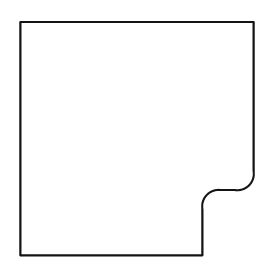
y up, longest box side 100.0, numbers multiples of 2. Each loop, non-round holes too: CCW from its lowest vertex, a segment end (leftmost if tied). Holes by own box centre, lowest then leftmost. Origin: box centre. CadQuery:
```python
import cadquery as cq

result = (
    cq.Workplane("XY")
    .moveTo(-50.0, -50.0)
    .lineTo(28.0, -50.0)
    .lineTo(28.0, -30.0)
    .threePointArc((30.0, -24.0), (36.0, -22.0))
    .lineTo(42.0, -22.0)
    .threePointArc((48.0, -20.0), (50.0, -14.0))
    .lineTo(50.0, 50.0)
    .lineTo(-50.0, 50.0)
    .close()
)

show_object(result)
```